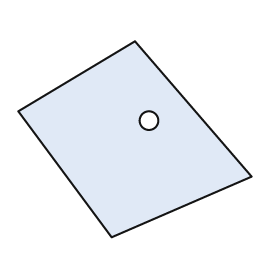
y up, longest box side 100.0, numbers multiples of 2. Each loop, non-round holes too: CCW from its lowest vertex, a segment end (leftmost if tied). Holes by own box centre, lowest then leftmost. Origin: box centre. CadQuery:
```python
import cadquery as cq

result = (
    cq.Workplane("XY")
    .moveTo(-10.0, -42.0)
    .lineTo(50.0, -16.0)
    .lineTo(0.0, 42.0)
    .lineTo(-50.0, 12.0)
    .close()
    .moveTo(6.0, 8.0)
    .circle(4.0)
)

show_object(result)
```